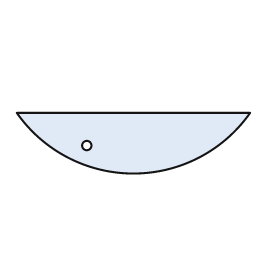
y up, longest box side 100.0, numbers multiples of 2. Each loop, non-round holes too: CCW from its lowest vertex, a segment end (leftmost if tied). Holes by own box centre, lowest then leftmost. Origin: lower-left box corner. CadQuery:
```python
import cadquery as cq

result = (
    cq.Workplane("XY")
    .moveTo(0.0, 26.0)
    .threePointArc((50.0, 0.0), (100.0, 26.0))
    .close()
    .moveTo(30.0, 12.0)
    .circle(2.0)
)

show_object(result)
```